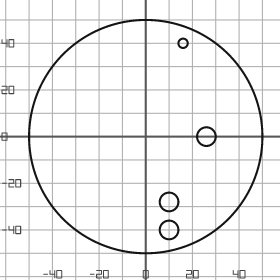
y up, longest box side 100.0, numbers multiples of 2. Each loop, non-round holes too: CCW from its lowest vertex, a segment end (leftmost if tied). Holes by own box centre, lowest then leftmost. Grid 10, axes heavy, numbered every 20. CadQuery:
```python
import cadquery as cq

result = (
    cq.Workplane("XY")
    .moveTo(0.0, 0.0)
    .circle(50.0)
    .moveTo(10.0, -40.0)
    .circle(4.0)
    .moveTo(10.0, -28.0)
    .circle(4.0)
    .moveTo(26.0, 0.0)
    .circle(4.0)
    .moveTo(16.0, 40.0)
    .circle(2.0)
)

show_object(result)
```